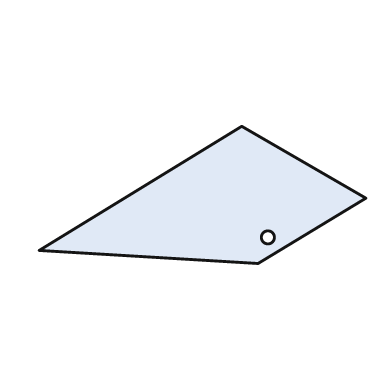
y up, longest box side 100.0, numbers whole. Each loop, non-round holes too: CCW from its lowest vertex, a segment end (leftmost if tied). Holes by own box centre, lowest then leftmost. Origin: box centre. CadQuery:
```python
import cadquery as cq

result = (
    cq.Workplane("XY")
    .moveTo(17.0, -21.0)
    .lineTo(50.0, -1.0)
    .lineTo(12.0, 21.0)
    .lineTo(-50.0, -17.0)
    .close()
    .moveTo(20.0, -13.0)
    .circle(2.0)
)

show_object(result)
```